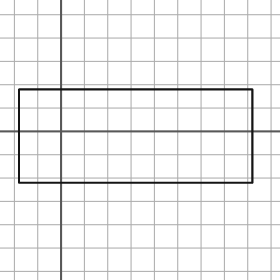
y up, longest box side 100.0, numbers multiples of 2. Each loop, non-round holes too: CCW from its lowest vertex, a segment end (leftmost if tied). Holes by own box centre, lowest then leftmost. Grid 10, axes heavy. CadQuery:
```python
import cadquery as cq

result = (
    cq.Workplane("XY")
    .moveTo(-18.0, -22.0)
    .lineTo(82.0, -22.0)
    .lineTo(82.0, 18.0)
    .lineTo(-18.0, 18.0)
    .close()
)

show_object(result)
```